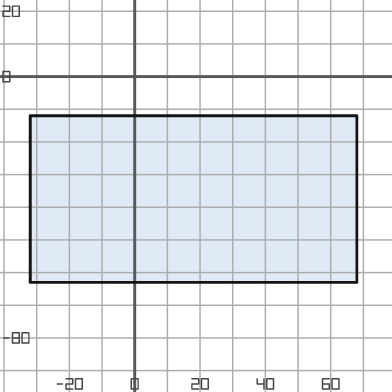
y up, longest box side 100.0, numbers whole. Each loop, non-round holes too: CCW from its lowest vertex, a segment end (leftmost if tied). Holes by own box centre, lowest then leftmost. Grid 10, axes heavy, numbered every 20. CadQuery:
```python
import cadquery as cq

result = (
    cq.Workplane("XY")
    .moveTo(-32.0, -63.0)
    .lineTo(68.0, -63.0)
    .lineTo(68.0, -12.0)
    .lineTo(-32.0, -12.0)
    .close()
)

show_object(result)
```